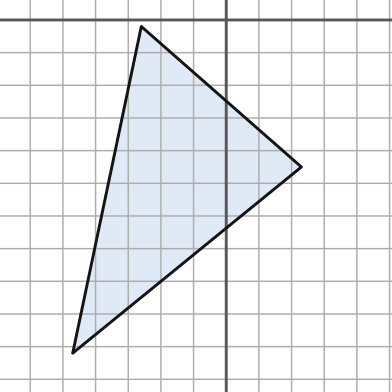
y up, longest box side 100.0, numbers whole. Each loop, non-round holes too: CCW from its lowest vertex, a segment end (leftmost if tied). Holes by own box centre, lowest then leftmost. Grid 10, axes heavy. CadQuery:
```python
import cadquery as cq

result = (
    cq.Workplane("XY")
    .moveTo(-47.0, -102.0)
    .lineTo(23.0, -45.0)
    .lineTo(-26.0, -2.0)
    .close()
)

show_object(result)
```